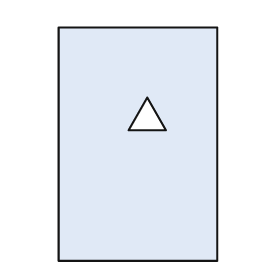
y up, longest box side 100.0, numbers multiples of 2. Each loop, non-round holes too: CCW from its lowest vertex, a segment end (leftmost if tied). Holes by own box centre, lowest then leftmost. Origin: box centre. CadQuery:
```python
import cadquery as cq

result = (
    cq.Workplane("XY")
    .moveTo(-34.0, -50.0)
    .lineTo(34.0, -50.0)
    .lineTo(34.0, 50.0)
    .lineTo(-34.0, 50.0)
    .close()
    .moveTo(-4.0, 6.0)
    .lineTo(12.0, 6.0)
    .lineTo(4.0, 20.0)
    .close()
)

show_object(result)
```